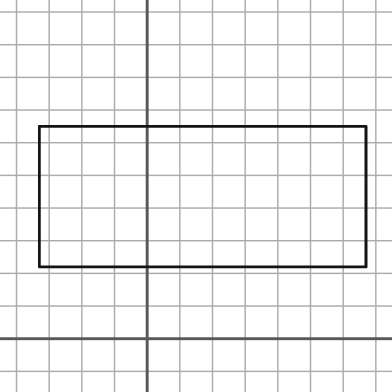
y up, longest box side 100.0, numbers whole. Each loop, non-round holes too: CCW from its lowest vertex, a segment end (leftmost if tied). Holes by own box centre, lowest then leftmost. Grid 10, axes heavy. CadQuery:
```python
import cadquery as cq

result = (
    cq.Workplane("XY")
    .moveTo(-33.0, 22.0)
    .lineTo(67.0, 22.0)
    .lineTo(67.0, 65.0)
    .lineTo(-33.0, 65.0)
    .close()
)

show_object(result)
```